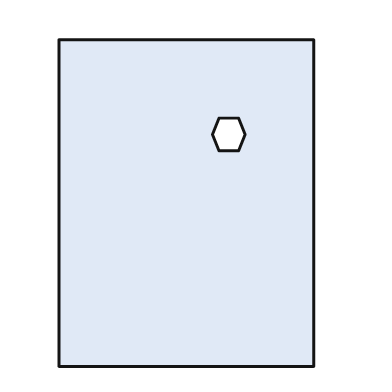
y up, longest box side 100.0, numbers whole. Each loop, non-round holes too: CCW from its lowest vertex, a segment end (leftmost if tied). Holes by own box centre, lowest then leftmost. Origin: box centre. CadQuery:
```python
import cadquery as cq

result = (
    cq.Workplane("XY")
    .moveTo(-39.0, -50.0)
    .lineTo(39.0, -50.0)
    .lineTo(39.0, 50.0)
    .lineTo(-39.0, 50.0)
    .close()
    .moveTo(10.0, 16.0)
    .lineTo(16.0, 16.0)
    .lineTo(18.0, 21.0)
    .lineTo(16.0, 26.0)
    .lineTo(10.0, 26.0)
    .lineTo(8.0, 21.0)
    .close()
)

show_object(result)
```